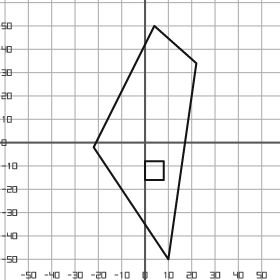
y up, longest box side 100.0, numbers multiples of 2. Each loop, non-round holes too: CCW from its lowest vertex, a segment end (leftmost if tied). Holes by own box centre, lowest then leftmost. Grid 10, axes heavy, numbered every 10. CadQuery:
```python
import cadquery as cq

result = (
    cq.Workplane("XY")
    .moveTo(10.0, -50.0)
    .lineTo(22.0, 34.0)
    .lineTo(4.0, 50.0)
    .lineTo(-22.0, -2.0)
    .close()
    .moveTo(0.0, -16.0)
    .lineTo(8.0, -16.0)
    .lineTo(8.0, -8.0)
    .lineTo(0.0, -8.0)
    .close()
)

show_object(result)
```